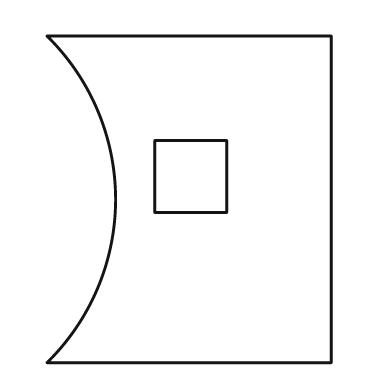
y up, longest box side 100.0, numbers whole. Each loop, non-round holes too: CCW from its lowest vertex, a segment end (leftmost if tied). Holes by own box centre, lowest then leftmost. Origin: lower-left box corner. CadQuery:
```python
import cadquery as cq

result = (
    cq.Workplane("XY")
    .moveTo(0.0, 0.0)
    .lineTo(87.0, 0.0)
    .lineTo(87.0, 100.0)
    .lineTo(0.0, 100.0)
    .threePointArc((21.0, 50.0), (0.0, 0.0))
    .close()
    .moveTo(33.0, 46.0)
    .lineTo(55.0, 46.0)
    .lineTo(55.0, 68.0)
    .lineTo(33.0, 68.0)
    .close()
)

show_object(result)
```